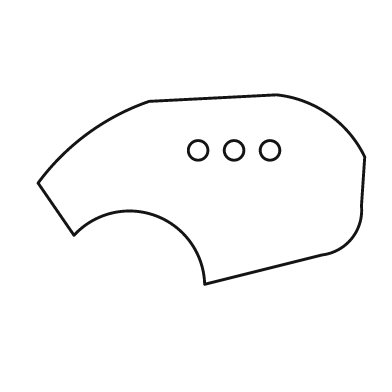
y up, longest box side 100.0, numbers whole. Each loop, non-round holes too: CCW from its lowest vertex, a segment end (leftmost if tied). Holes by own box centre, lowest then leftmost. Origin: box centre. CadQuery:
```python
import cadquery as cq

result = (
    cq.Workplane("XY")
    .moveTo(1.0, -29.0)
    .lineTo(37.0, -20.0)
    .threePointArc((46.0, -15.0), (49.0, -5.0))
    .lineTo(50.0, 10.0)
    .threePointArc((39.0, 23.0), (23.0, 29.0))
    .lineTo(-16.0, 27.0)
    .threePointArc((-35.0, 17.0), (-50.0, 2.0))
    .lineTo(-39.0, -14.0)
    .threePointArc((-14.0, -8.0), (1.0, -29.0))
    .close()
    .moveTo(-1.0, 12.0)
    .circle(3.0)
    .moveTo(10.0, 12.0)
    .circle(3.0)
    .moveTo(21.0, 12.0)
    .circle(3.0)
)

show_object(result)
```